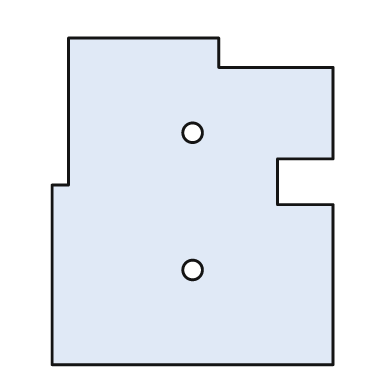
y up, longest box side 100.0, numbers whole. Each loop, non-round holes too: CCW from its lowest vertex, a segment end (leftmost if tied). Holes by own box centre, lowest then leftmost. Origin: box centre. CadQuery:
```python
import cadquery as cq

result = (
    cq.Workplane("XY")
    .moveTo(-43.0, -50.0)
    .lineTo(43.0, -50.0)
    .lineTo(43.0, -1.0)
    .lineTo(26.0, -1.0)
    .lineTo(26.0, 13.0)
    .lineTo(43.0, 13.0)
    .lineTo(43.0, 41.0)
    .lineTo(8.0, 41.0)
    .lineTo(8.0, 50.0)
    .lineTo(-38.0, 50.0)
    .lineTo(-38.0, 5.0)
    .lineTo(-43.0, 5.0)
    .close()
    .moveTo(0.0, -21.0)
    .circle(3.0)
    .moveTo(0.0, 21.0)
    .circle(3.0)
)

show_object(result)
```